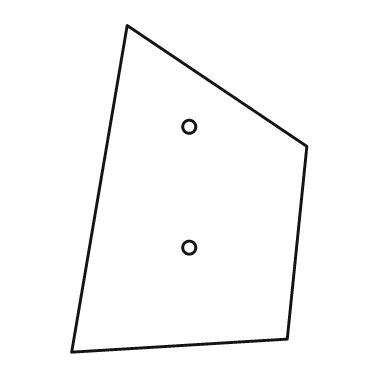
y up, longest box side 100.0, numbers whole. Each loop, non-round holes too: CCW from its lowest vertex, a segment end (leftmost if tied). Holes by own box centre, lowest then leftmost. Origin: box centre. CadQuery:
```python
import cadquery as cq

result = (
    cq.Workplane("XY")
    .moveTo(-36.0, -50.0)
    .lineTo(30.0, -46.0)
    .lineTo(36.0, 13.0)
    .lineTo(-19.0, 50.0)
    .close()
    .moveTo(0.0, -18.0)
    .circle(2.0)
    .moveTo(0.0, 19.0)
    .circle(2.0)
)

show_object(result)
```